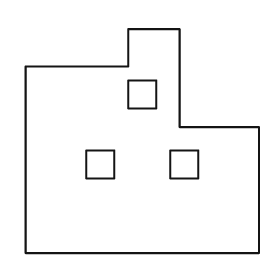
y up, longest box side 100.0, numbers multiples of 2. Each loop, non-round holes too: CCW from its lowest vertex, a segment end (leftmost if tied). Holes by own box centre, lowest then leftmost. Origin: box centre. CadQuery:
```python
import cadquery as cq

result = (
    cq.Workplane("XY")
    .moveTo(-50.0, -48.0)
    .lineTo(50.0, -48.0)
    .lineTo(50.0, 6.0)
    .lineTo(16.0, 6.0)
    .lineTo(16.0, 48.0)
    .lineTo(-6.0, 48.0)
    .lineTo(-6.0, 32.0)
    .lineTo(-50.0, 32.0)
    .close()
    .moveTo(-24.0, -16.0)
    .lineTo(-12.0, -16.0)
    .lineTo(-12.0, -4.0)
    .lineTo(-24.0, -4.0)
    .close()
    .moveTo(12.0, -16.0)
    .lineTo(24.0, -16.0)
    .lineTo(24.0, -4.0)
    .lineTo(12.0, -4.0)
    .close()
    .moveTo(-6.0, 14.0)
    .lineTo(6.0, 14.0)
    .lineTo(6.0, 26.0)
    .lineTo(-6.0, 26.0)
    .close()
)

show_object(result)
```